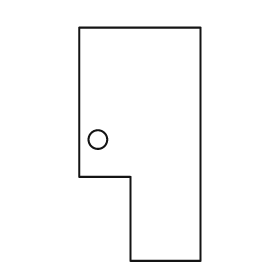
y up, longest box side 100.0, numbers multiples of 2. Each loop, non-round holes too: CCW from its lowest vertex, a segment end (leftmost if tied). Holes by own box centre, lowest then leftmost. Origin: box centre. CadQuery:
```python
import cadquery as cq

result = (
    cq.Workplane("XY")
    .moveTo(-4.0, -50.0)
    .lineTo(26.0, -50.0)
    .lineTo(26.0, 50.0)
    .lineTo(-26.0, 50.0)
    .lineTo(-26.0, -14.0)
    .lineTo(-4.0, -14.0)
    .close()
    .moveTo(-18.0, 2.0)
    .circle(4.0)
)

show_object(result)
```